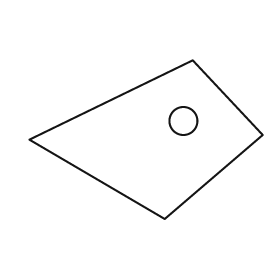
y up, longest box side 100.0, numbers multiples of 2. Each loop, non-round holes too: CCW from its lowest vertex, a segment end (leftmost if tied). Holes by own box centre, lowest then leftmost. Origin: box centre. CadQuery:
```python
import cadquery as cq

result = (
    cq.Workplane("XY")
    .moveTo(8.0, -34.0)
    .lineTo(50.0, 2.0)
    .lineTo(20.0, 34.0)
    .lineTo(-50.0, 0.0)
    .close()
    .moveTo(16.0, 8.0)
    .circle(6.0)
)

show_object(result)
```